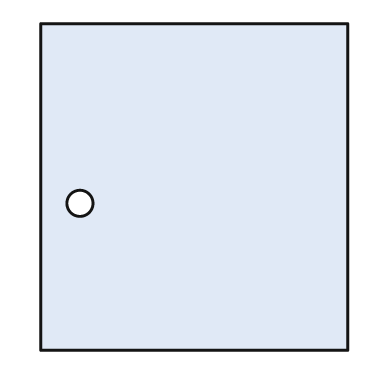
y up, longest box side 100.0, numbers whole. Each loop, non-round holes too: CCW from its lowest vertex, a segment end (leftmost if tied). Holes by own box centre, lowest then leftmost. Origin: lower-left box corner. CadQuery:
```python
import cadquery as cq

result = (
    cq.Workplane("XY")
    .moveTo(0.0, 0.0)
    .lineTo(94.0, 0.0)
    .lineTo(94.0, 100.0)
    .lineTo(0.0, 100.0)
    .close()
    .moveTo(12.0, 45.0)
    .circle(4.0)
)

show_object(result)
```